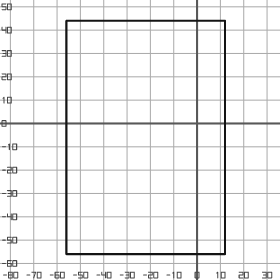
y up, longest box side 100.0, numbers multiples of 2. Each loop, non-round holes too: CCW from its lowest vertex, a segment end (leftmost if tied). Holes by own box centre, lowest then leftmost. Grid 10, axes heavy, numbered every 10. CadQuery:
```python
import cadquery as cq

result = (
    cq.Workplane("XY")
    .moveTo(-56.0, -56.0)
    .lineTo(12.0, -56.0)
    .lineTo(12.0, 44.0)
    .lineTo(-56.0, 44.0)
    .close()
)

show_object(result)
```